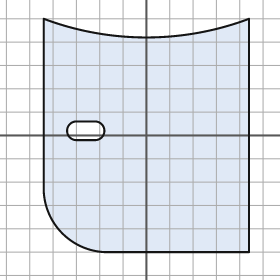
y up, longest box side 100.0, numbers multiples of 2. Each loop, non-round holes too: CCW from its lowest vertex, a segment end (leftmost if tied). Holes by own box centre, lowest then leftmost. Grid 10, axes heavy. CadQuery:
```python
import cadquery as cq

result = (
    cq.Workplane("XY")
    .moveTo(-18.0, -50.0)
    .lineTo(44.0, -50.0)
    .lineTo(44.0, 50.0)
    .threePointArc((0.0, 42.0), (-44.0, 50.0))
    .lineTo(-44.0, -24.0)
    .threePointArc((-36.0, -42.0), (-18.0, -50.0))
    .close()
    .moveTo(-30.0, -2.0)
    .lineTo(-22.0, -2.0)
    .threePointArc((-18.0, 2.0), (-22.0, 6.0))
    .lineTo(-30.0, 6.0)
    .threePointArc((-34.0, 2.0), (-30.0, -2.0))
    .close()
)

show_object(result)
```